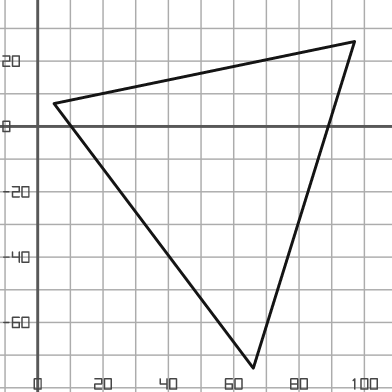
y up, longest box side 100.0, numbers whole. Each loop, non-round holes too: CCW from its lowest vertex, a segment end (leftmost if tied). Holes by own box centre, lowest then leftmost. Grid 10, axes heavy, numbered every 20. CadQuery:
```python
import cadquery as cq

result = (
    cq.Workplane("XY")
    .moveTo(66.0, -74.0)
    .lineTo(97.0, 26.0)
    .lineTo(5.0, 7.0)
    .close()
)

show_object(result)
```